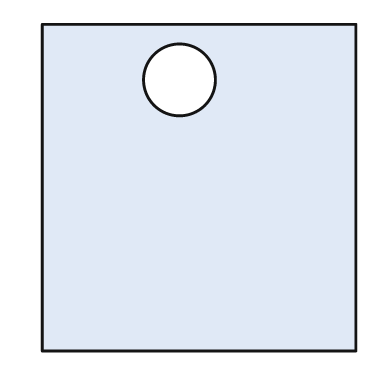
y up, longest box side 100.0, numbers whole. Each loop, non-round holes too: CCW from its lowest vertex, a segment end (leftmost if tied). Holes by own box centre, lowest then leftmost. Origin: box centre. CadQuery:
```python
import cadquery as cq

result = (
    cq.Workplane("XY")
    .moveTo(-48.0, -50.0)
    .lineTo(48.0, -50.0)
    .lineTo(48.0, 50.0)
    .lineTo(-48.0, 50.0)
    .close()
    .moveTo(-6.0, 33.0)
    .circle(11.0)
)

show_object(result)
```